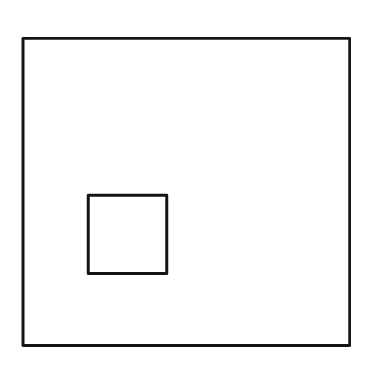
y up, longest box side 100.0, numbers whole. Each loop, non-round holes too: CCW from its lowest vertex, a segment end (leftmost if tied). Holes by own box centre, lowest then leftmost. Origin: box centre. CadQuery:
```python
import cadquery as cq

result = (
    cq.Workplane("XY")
    .moveTo(-50.0, -47.0)
    .lineTo(50.0, -47.0)
    .lineTo(50.0, 47.0)
    .lineTo(-50.0, 47.0)
    .close()
    .moveTo(-30.0, -25.0)
    .lineTo(-6.0, -25.0)
    .lineTo(-6.0, -1.0)
    .lineTo(-30.0, -1.0)
    .close()
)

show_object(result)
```